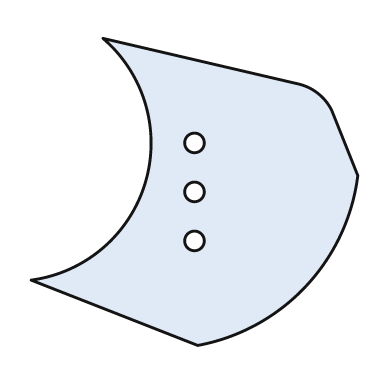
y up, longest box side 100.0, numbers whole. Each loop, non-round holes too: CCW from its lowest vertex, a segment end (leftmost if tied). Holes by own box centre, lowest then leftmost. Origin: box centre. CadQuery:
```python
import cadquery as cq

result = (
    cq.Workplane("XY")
    .moveTo(1.0, -47.0)
    .threePointArc((34.0, -29.0), (50.0, 5.0))
    .lineTo(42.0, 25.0)
    .threePointArc((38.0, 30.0), (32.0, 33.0))
    .lineTo(-28.0, 47.0)
    .threePointArc((-15.0, 3.0), (-50.0, -27.0))
    .close()
    .moveTo(0.0, -15.0)
    .circle(3.0)
    .moveTo(0.0, 0.0)
    .circle(3.0)
    .moveTo(0.0, 15.0)
    .circle(3.0)
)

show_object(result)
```